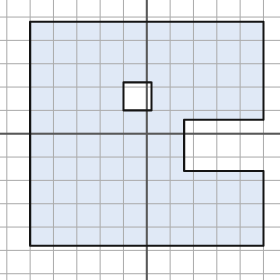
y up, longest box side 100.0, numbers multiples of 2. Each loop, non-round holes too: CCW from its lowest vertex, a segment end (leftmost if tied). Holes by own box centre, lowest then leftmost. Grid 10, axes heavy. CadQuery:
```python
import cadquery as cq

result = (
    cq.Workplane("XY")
    .moveTo(-50.0, -48.0)
    .lineTo(50.0, -48.0)
    .lineTo(50.0, -16.0)
    .lineTo(16.0, -16.0)
    .lineTo(16.0, 6.0)
    .lineTo(50.0, 6.0)
    .lineTo(50.0, 48.0)
    .lineTo(-50.0, 48.0)
    .close()
    .moveTo(-10.0, 10.0)
    .lineTo(2.0, 10.0)
    .lineTo(2.0, 22.0)
    .lineTo(-10.0, 22.0)
    .close()
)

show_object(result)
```